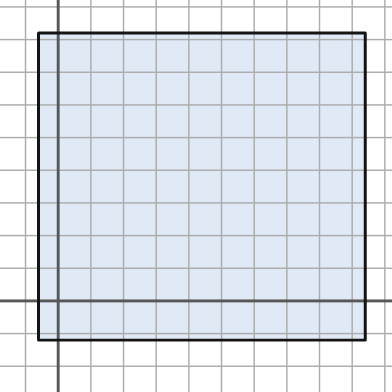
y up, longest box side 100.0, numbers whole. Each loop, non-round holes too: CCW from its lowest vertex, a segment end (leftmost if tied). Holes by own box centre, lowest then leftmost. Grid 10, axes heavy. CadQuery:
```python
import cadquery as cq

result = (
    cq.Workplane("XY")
    .moveTo(-6.0, -12.0)
    .lineTo(94.0, -12.0)
    .lineTo(94.0, 82.0)
    .lineTo(-6.0, 82.0)
    .close()
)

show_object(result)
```